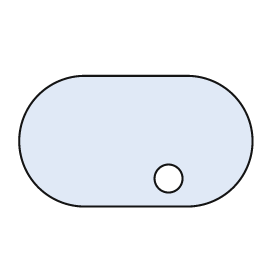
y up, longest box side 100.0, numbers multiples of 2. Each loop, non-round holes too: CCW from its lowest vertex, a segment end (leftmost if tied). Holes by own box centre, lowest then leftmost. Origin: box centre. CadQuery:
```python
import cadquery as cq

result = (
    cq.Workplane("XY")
    .moveTo(-22.0, -28.0)
    .lineTo(22.0, -28.0)
    .threePointArc((50.0, 0.0), (22.0, 28.0))
    .lineTo(-22.0, 28.0)
    .threePointArc((-50.0, 0.0), (-22.0, -28.0))
    .close()
    .moveTo(14.0, -16.0)
    .circle(6.0)
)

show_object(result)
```